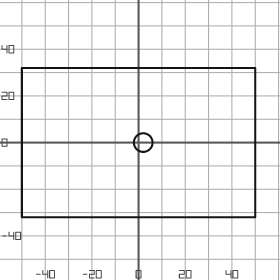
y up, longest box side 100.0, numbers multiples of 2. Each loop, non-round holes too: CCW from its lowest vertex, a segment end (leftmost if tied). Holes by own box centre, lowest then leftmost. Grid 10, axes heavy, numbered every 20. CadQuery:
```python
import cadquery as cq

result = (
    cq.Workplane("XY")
    .moveTo(-50.0, -32.0)
    .lineTo(50.0, -32.0)
    .lineTo(50.0, 32.0)
    .lineTo(-50.0, 32.0)
    .close()
    .moveTo(2.0, 0.0)
    .circle(4.0)
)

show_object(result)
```